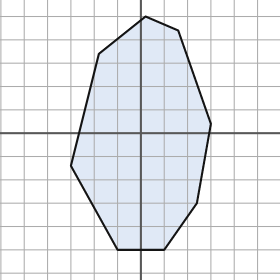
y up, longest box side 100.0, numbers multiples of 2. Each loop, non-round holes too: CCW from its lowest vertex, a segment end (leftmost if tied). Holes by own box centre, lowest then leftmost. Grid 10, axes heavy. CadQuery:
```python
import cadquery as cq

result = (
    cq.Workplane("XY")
    .moveTo(-10.0, -50.0)
    .lineTo(10.0, -50.0)
    .lineTo(24.0, -30.0)
    .lineTo(30.0, 4.0)
    .lineTo(16.0, 44.0)
    .lineTo(2.0, 50.0)
    .lineTo(-18.0, 34.0)
    .lineTo(-30.0, -14.0)
    .close()
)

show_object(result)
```